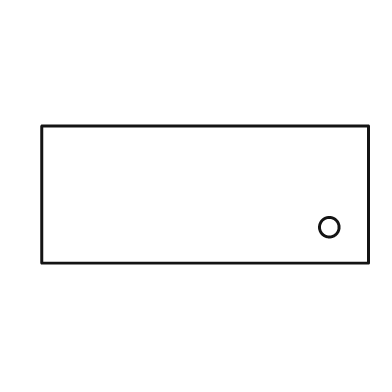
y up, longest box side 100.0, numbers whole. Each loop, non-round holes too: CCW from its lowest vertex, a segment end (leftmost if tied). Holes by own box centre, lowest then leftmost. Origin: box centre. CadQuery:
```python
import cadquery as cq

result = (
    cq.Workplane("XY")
    .moveTo(-50.0, -21.0)
    .lineTo(50.0, -21.0)
    .lineTo(50.0, 21.0)
    .lineTo(-50.0, 21.0)
    .close()
    .moveTo(38.0, -10.0)
    .circle(3.0)
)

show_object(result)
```